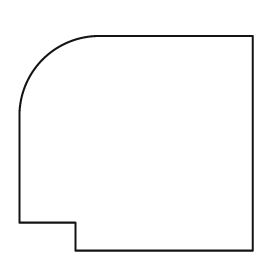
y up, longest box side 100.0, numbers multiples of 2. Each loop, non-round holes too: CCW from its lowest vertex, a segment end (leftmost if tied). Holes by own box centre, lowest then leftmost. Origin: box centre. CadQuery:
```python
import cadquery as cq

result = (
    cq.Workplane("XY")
    .moveTo(-26.0, -46.0)
    .lineTo(50.0, -46.0)
    .lineTo(50.0, 46.0)
    .lineTo(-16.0, 46.0)
    .threePointArc((-40.0, 36.0), (-50.0, 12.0))
    .lineTo(-50.0, -34.0)
    .lineTo(-26.0, -34.0)
    .close()
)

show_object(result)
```